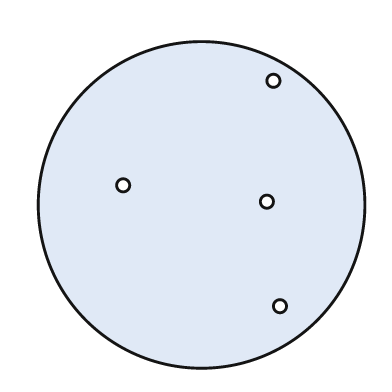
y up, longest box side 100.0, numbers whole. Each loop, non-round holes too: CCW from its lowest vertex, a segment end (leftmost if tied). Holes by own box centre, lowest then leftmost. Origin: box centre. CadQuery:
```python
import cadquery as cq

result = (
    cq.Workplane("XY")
    .moveTo(0.0, 0.0)
    .circle(50.0)
    .moveTo(24.0, -31.0)
    .circle(2.0)
    .moveTo(20.0, 1.0)
    .circle(2.0)
    .moveTo(-24.0, 6.0)
    .circle(2.0)
    .moveTo(22.0, 38.0)
    .circle(2.0)
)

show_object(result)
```